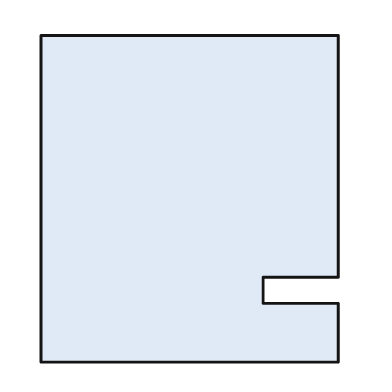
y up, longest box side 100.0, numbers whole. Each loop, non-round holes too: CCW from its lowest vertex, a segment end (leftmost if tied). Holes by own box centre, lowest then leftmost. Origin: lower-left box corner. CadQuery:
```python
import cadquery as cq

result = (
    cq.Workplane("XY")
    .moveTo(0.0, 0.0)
    .lineTo(91.0, 0.0)
    .lineTo(91.0, 18.0)
    .lineTo(68.0, 18.0)
    .lineTo(68.0, 26.0)
    .lineTo(91.0, 26.0)
    .lineTo(91.0, 100.0)
    .lineTo(0.0, 100.0)
    .close()
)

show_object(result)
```